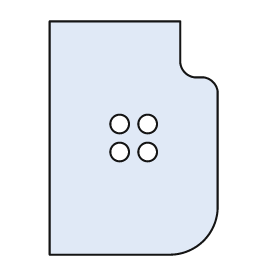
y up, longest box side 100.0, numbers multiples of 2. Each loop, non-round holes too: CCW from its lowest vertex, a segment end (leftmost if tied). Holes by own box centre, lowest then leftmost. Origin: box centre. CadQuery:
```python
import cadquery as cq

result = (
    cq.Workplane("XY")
    .moveTo(-36.0, -50.0)
    .lineTo(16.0, -50.0)
    .threePointArc((30.0, -44.0), (36.0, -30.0))
    .lineTo(36.0, 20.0)
    .threePointArc((34.0, 24.0), (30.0, 26.0))
    .lineTo(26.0, 26.0)
    .threePointArc((22.0, 28.0), (20.0, 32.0))
    .lineTo(20.0, 50.0)
    .lineTo(-36.0, 50.0)
    .close()
    .moveTo(-6.0, -6.0)
    .circle(4.0)
    .moveTo(6.0, -6.0)
    .circle(4.0)
    .moveTo(-6.0, 6.0)
    .circle(4.0)
    .moveTo(6.0, 6.0)
    .circle(4.0)
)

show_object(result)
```